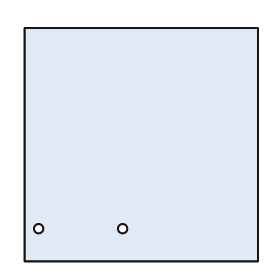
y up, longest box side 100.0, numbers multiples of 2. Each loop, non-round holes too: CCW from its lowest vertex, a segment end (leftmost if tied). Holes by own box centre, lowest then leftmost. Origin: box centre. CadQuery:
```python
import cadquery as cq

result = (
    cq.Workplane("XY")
    .moveTo(-50.0, -50.0)
    .lineTo(50.0, -50.0)
    .lineTo(50.0, 50.0)
    .lineTo(-50.0, 50.0)
    .close()
    .moveTo(-44.0, -36.0)
    .circle(2.0)
    .moveTo(-8.0, -36.0)
    .circle(2.0)
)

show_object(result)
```